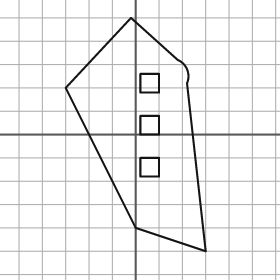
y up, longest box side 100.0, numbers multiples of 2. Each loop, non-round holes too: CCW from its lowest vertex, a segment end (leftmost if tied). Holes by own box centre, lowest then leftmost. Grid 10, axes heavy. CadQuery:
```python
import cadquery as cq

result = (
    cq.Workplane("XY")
    .moveTo(30.0, -50.0)
    .lineTo(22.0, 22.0)
    .threePointArc((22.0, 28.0), (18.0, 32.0))
    .lineTo(-2.0, 50.0)
    .lineTo(-30.0, 20.0)
    .lineTo(0.0, -40.0)
    .close()
    .moveTo(2.0, -18.0)
    .lineTo(10.0, -18.0)
    .lineTo(10.0, -10.0)
    .lineTo(2.0, -10.0)
    .close()
    .moveTo(2.0, 0.0)
    .lineTo(10.0, 0.0)
    .lineTo(10.0, 8.0)
    .lineTo(2.0, 8.0)
    .close()
    .moveTo(2.0, 18.0)
    .lineTo(10.0, 18.0)
    .lineTo(10.0, 26.0)
    .lineTo(2.0, 26.0)
    .close()
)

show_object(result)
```